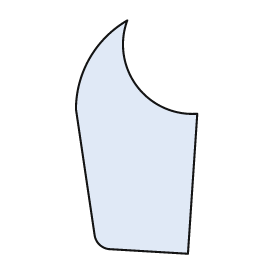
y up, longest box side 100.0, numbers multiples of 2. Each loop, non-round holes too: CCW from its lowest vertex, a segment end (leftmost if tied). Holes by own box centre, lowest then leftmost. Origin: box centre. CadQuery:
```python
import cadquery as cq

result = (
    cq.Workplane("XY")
    .moveTo(22.0, -50.0)
    .lineTo(26.0, 10.0)
    .threePointArc((0.0, 22.0), (-4.0, 50.0))
    .threePointArc((-20.0, 34.0), (-26.0, 12.0))
    .lineTo(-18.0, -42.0)
    .threePointArc((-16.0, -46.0), (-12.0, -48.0))
    .close()
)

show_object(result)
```